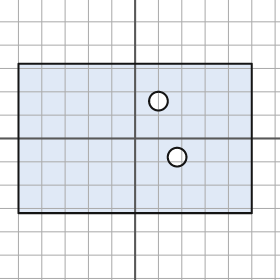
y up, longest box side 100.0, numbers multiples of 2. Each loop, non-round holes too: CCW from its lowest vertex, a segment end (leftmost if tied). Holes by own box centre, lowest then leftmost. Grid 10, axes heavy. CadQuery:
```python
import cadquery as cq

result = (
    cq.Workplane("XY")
    .moveTo(-50.0, -32.0)
    .lineTo(50.0, -32.0)
    .lineTo(50.0, 32.0)
    .lineTo(-50.0, 32.0)
    .close()
    .moveTo(18.0, -8.0)
    .circle(4.0)
    .moveTo(10.0, 16.0)
    .circle(4.0)
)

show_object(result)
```